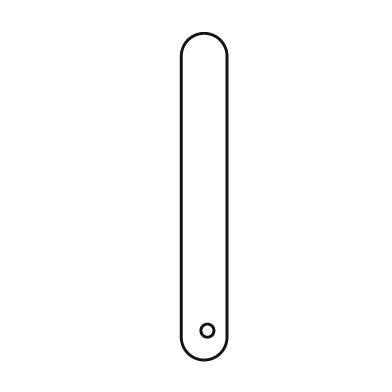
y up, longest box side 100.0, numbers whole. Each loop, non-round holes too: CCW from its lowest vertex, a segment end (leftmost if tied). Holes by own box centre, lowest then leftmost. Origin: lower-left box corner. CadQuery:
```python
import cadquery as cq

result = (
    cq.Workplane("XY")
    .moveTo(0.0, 7.0)
    .threePointArc((7.0, 0.0), (14.0, 7.0))
    .lineTo(14.0, 93.0)
    .threePointArc((7.0, 100.0), (0.0, 93.0))
    .close()
    .moveTo(8.0, 9.0)
    .circle(2.0)
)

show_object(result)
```